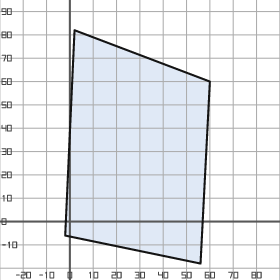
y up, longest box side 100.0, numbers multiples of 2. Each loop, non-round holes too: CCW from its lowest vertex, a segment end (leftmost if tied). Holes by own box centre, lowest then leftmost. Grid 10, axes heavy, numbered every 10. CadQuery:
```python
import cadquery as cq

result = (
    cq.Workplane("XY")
    .moveTo(56.0, -18.0)
    .lineTo(60.0, 60.0)
    .lineTo(2.0, 82.0)
    .lineTo(-2.0, -6.0)
    .close()
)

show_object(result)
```